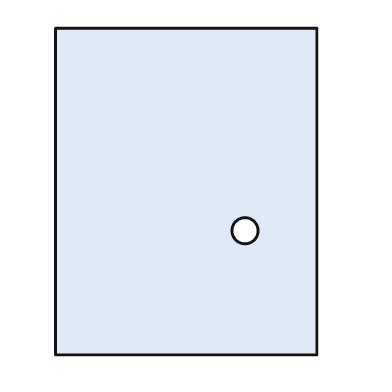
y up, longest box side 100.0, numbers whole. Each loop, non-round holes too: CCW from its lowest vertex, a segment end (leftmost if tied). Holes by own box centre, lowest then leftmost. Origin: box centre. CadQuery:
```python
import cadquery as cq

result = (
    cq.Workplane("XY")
    .moveTo(-40.0, -50.0)
    .lineTo(40.0, -50.0)
    .lineTo(40.0, 50.0)
    .lineTo(-40.0, 50.0)
    .close()
    .moveTo(18.0, -12.0)
    .circle(4.0)
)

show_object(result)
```